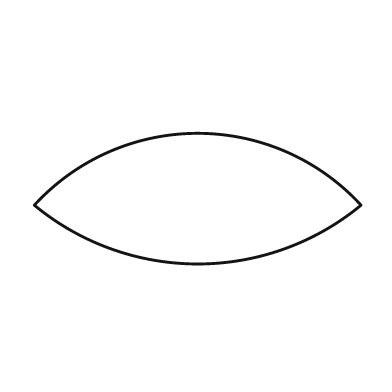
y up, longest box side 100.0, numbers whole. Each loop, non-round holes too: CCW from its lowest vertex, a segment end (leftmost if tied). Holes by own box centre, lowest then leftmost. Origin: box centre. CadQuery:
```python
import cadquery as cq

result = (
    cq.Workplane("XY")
    .moveTo(-50.0, -2.0)
    .threePointArc((0.0, -20.0), (50.0, -2.0))
    .threePointArc((0.0, 20.0), (-50.0, -2.0))
    .close()
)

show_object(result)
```